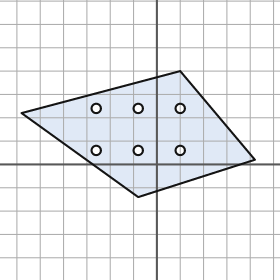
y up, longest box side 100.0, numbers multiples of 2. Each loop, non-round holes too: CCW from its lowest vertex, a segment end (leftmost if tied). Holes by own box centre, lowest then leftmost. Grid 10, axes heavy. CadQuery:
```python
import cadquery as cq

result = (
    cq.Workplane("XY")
    .moveTo(-8.0, -14.0)
    .lineTo(42.0, 2.0)
    .lineTo(10.0, 40.0)
    .lineTo(-58.0, 22.0)
    .close()
    .moveTo(-26.0, 6.0)
    .circle(2.0)
    .moveTo(-8.0, 6.0)
    .circle(2.0)
    .moveTo(10.0, 6.0)
    .circle(2.0)
    .moveTo(-26.0, 24.0)
    .circle(2.0)
    .moveTo(-8.0, 24.0)
    .circle(2.0)
    .moveTo(10.0, 24.0)
    .circle(2.0)
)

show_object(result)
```